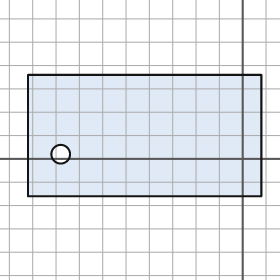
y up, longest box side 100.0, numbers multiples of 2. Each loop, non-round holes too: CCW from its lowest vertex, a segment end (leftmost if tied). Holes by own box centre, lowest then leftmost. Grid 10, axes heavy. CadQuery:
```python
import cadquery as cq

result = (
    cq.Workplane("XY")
    .moveTo(-92.0, -16.0)
    .lineTo(8.0, -16.0)
    .lineTo(8.0, 36.0)
    .lineTo(-92.0, 36.0)
    .close()
    .moveTo(-78.0, 2.0)
    .circle(4.0)
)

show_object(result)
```